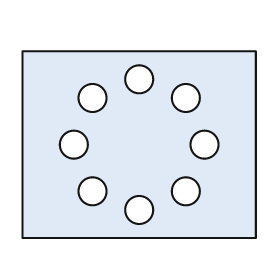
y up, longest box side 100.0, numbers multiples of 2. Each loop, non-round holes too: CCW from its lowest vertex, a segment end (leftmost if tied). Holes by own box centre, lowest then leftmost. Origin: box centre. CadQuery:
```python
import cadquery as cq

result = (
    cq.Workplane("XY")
    .moveTo(-50.0, -40.0)
    .lineTo(50.0, -40.0)
    .lineTo(50.0, 40.0)
    .lineTo(-50.0, 40.0)
    .close()
    .moveTo(0.0, -28.0)
    .circle(6.0)
    .moveTo(-20.0, -20.0)
    .circle(6.0)
    .moveTo(20.0, -20.0)
    .circle(6.0)
    .moveTo(-28.0, 0.0)
    .circle(6.0)
    .moveTo(28.0, 0.0)
    .circle(6.0)
    .moveTo(-20.0, 20.0)
    .circle(6.0)
    .moveTo(20.0, 20.0)
    .circle(6.0)
    .moveTo(0.0, 28.0)
    .circle(6.0)
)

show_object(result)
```